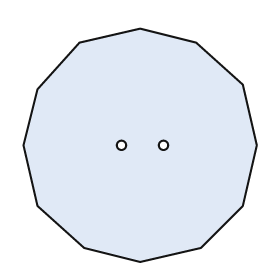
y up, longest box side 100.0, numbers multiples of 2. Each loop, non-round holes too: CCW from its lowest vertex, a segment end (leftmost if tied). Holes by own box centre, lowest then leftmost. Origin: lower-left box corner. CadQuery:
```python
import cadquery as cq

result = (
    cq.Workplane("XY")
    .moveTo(50.0, 0.0)
    .lineTo(76.0, 6.0)
    .lineTo(94.0, 24.0)
    .lineTo(100.0, 50.0)
    .lineTo(94.0, 76.0)
    .lineTo(74.0, 94.0)
    .lineTo(50.0, 100.0)
    .lineTo(24.0, 94.0)
    .lineTo(6.0, 74.0)
    .lineTo(0.0, 50.0)
    .lineTo(6.0, 24.0)
    .lineTo(26.0, 6.0)
    .close()
    .moveTo(42.0, 50.0)
    .circle(2.0)
    .moveTo(60.0, 50.0)
    .circle(2.0)
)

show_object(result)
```